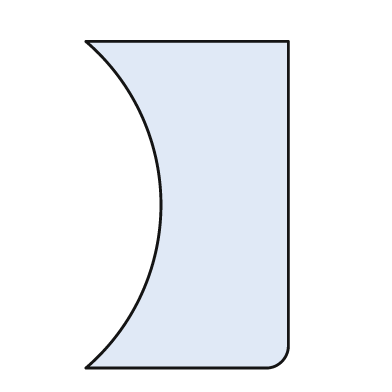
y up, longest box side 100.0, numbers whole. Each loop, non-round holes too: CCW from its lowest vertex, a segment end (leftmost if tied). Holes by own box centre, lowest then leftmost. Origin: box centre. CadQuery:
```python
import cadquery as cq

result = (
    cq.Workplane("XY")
    .moveTo(-31.0, -50.0)
    .lineTo(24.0, -50.0)
    .threePointArc((29.0, -48.0), (31.0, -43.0))
    .lineTo(31.0, 50.0)
    .lineTo(-31.0, 50.0)
    .threePointArc((-8.0, 0.0), (-31.0, -50.0))
    .close()
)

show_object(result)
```